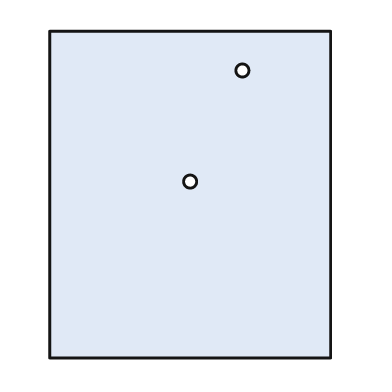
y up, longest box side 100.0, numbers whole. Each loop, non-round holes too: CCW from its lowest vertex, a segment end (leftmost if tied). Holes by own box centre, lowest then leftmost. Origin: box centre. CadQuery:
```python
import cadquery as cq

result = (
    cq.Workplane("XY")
    .moveTo(-43.0, -50.0)
    .lineTo(43.0, -50.0)
    .lineTo(43.0, 50.0)
    .lineTo(-43.0, 50.0)
    .close()
    .moveTo(0.0, 4.0)
    .circle(2.0)
    .moveTo(16.0, 38.0)
    .circle(2.0)
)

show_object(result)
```